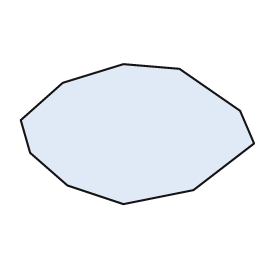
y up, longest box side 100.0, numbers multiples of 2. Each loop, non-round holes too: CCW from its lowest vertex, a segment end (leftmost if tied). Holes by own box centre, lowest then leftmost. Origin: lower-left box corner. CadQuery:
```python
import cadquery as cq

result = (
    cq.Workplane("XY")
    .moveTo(44.0, 0.0)
    .lineTo(74.0, 6.0)
    .lineTo(100.0, 26.0)
    .lineTo(94.0, 40.0)
    .lineTo(68.0, 58.0)
    .lineTo(44.0, 60.0)
    .lineTo(18.0, 52.0)
    .lineTo(0.0, 36.0)
    .lineTo(4.0, 22.0)
    .lineTo(20.0, 8.0)
    .close()
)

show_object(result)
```